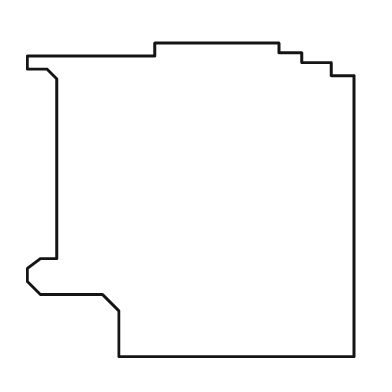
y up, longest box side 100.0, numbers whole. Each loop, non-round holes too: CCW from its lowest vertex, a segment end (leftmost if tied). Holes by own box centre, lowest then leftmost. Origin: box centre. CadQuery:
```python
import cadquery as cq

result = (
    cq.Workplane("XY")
    .moveTo(-22.0, -48.0)
    .lineTo(50.0, -48.0)
    .lineTo(50.0, 38.0)
    .lineTo(43.0, 38.0)
    .lineTo(43.0, 42.0)
    .lineTo(34.0, 42.0)
    .lineTo(34.0, 45.0)
    .lineTo(27.0, 45.0)
    .lineTo(27.0, 48.0)
    .lineTo(-11.0, 48.0)
    .lineTo(-11.0, 44.0)
    .lineTo(-50.0, 44.0)
    .lineTo(-50.0, 40.0)
    .lineTo(-44.0, 40.0)
    .lineTo(-41.0, 37.0)
    .lineTo(-41.0, -18.0)
    .lineTo(-46.0, -18.0)
    .lineTo(-50.0, -21.0)
    .lineTo(-50.0, -25.0)
    .lineTo(-46.0, -29.0)
    .lineTo(-27.0, -29.0)
    .lineTo(-22.0, -34.0)
    .close()
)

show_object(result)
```